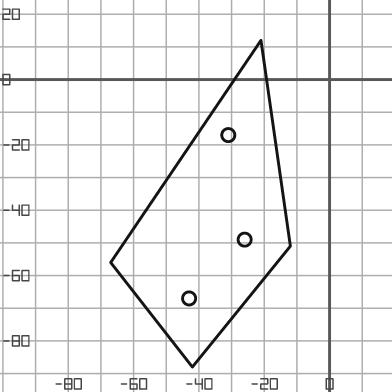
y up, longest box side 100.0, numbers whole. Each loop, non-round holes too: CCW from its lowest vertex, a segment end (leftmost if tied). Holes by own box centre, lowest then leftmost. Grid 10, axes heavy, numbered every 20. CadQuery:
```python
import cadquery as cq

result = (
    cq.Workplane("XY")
    .moveTo(-42.0, -88.0)
    .lineTo(-12.0, -51.0)
    .lineTo(-21.0, 12.0)
    .lineTo(-67.0, -56.0)
    .close()
    .moveTo(-43.0, -67.0)
    .circle(2.0)
    .moveTo(-26.0, -49.0)
    .circle(2.0)
    .moveTo(-31.0, -17.0)
    .circle(2.0)
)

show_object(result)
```